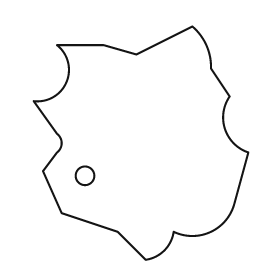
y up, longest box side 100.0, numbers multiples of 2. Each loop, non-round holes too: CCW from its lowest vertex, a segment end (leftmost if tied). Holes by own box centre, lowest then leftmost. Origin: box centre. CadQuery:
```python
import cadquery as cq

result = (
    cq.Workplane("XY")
    .moveTo(2.0, -50.0)
    .threePointArc((10.0, -46.0), (14.0, -38.0))
    .threePointArc((30.0, -38.0), (40.0, -26.0))
    .lineTo(46.0, -4.0)
    .threePointArc((36.0, 6.0), (38.0, 20.0))
    .lineTo(30.0, 32.0)
    .threePointArc((28.0, 42.0), (22.0, 50.0))
    .lineTo(-2.0, 38.0)
    .lineTo(-16.0, 42.0)
    .lineTo(-36.0, 42.0)
    .threePointArc((-32.0, 26.0), (-46.0, 18.0))
    .lineTo(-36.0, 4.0)
    .threePointArc((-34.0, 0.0), (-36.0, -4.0))
    .lineTo(-42.0, -12.0)
    .lineTo(-34.0, -30.0)
    .lineTo(-10.0, -38.0)
    .close()
    .moveTo(-24.0, -14.0)
    .circle(4.0)
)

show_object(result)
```